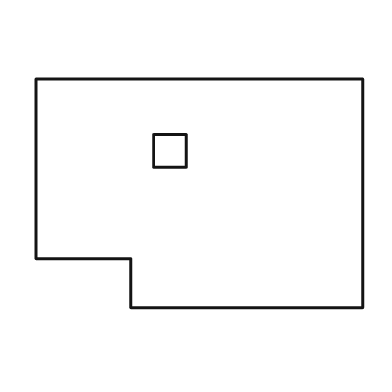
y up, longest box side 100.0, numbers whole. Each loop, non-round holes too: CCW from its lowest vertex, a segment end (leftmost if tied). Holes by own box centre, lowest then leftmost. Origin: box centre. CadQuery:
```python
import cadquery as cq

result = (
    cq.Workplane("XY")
    .moveTo(-21.0, -35.0)
    .lineTo(50.0, -35.0)
    .lineTo(50.0, 35.0)
    .lineTo(-50.0, 35.0)
    .lineTo(-50.0, -20.0)
    .lineTo(-21.0, -20.0)
    .close()
    .moveTo(-14.0, 8.0)
    .lineTo(-4.0, 8.0)
    .lineTo(-4.0, 18.0)
    .lineTo(-14.0, 18.0)
    .close()
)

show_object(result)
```